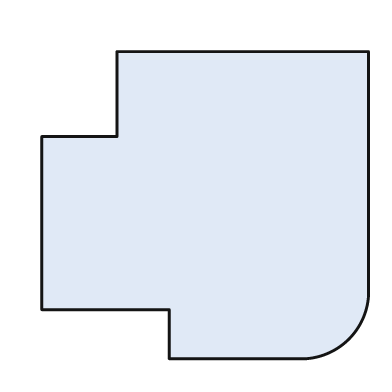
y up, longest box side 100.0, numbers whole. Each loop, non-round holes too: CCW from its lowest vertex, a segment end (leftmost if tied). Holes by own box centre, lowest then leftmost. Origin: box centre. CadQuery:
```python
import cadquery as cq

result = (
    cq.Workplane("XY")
    .moveTo(-11.0, -47.0)
    .lineTo(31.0, -47.0)
    .threePointArc((44.0, -41.0), (50.0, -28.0))
    .lineTo(50.0, 47.0)
    .lineTo(-27.0, 47.0)
    .lineTo(-27.0, 21.0)
    .lineTo(-50.0, 21.0)
    .lineTo(-50.0, -32.0)
    .lineTo(-11.0, -32.0)
    .close()
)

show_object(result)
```